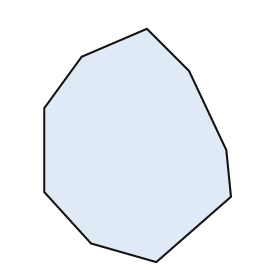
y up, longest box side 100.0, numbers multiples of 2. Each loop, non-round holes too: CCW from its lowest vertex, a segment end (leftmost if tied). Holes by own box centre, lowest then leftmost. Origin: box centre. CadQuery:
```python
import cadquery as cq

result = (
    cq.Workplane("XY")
    .moveTo(8.0, -50.0)
    .lineTo(40.0, -22.0)
    .lineTo(38.0, -2.0)
    .lineTo(22.0, 32.0)
    .lineTo(4.0, 50.0)
    .lineTo(-24.0, 38.0)
    .lineTo(-40.0, 16.0)
    .lineTo(-40.0, -20.0)
    .lineTo(-20.0, -42.0)
    .close()
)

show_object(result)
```